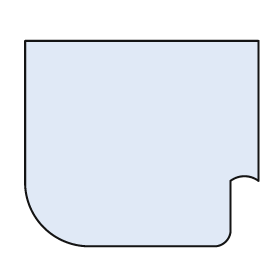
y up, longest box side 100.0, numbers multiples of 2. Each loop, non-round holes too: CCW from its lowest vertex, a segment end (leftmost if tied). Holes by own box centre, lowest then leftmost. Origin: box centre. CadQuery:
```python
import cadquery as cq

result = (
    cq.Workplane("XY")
    .moveTo(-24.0, -44.0)
    .lineTo(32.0, -44.0)
    .threePointArc((36.0, -42.0), (38.0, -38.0))
    .lineTo(38.0, -16.0)
    .threePointArc((44.0, -14.0), (50.0, -16.0))
    .lineTo(50.0, 44.0)
    .lineTo(-50.0, 44.0)
    .lineTo(-50.0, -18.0)
    .threePointArc((-42.0, -36.0), (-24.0, -44.0))
    .close()
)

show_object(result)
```